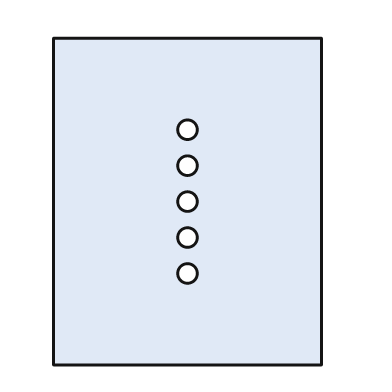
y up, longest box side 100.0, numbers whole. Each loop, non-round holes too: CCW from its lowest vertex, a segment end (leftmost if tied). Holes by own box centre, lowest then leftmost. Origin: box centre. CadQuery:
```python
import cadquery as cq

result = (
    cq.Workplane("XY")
    .moveTo(-41.0, -50.0)
    .lineTo(41.0, -50.0)
    .lineTo(41.0, 50.0)
    .lineTo(-41.0, 50.0)
    .close()
    .moveTo(0.0, -22.0)
    .circle(3.0)
    .moveTo(0.0, -11.0)
    .circle(3.0)
    .moveTo(0.0, 0.0)
    .circle(3.0)
    .moveTo(0.0, 11.0)
    .circle(3.0)
    .moveTo(0.0, 22.0)
    .circle(3.0)
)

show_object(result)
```